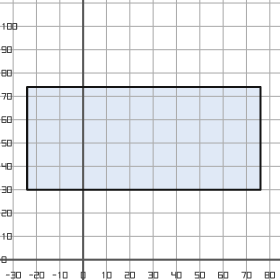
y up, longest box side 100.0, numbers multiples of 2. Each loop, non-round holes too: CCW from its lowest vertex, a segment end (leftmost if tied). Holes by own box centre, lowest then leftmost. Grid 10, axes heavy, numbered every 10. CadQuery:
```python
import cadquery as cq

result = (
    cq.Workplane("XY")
    .moveTo(-24.0, 30.0)
    .lineTo(76.0, 30.0)
    .lineTo(76.0, 74.0)
    .lineTo(-24.0, 74.0)
    .close()
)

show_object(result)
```